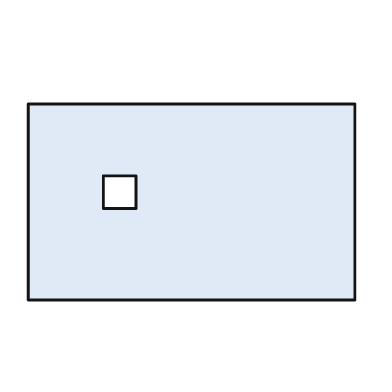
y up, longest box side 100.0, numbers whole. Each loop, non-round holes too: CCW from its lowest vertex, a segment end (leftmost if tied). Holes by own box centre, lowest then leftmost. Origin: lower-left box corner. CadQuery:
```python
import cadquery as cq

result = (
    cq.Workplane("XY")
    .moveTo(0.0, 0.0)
    .lineTo(100.0, 0.0)
    .lineTo(100.0, 60.0)
    .lineTo(0.0, 60.0)
    .close()
    .moveTo(23.0, 28.0)
    .lineTo(33.0, 28.0)
    .lineTo(33.0, 38.0)
    .lineTo(23.0, 38.0)
    .close()
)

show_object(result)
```